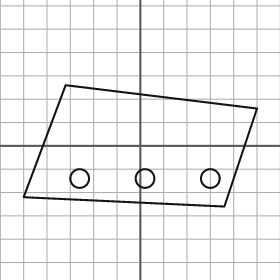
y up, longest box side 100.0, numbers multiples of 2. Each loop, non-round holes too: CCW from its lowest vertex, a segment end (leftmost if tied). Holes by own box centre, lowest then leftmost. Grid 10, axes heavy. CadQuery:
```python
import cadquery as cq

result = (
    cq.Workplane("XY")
    .moveTo(36.0, -26.0)
    .lineTo(50.0, 16.0)
    .lineTo(-32.0, 26.0)
    .lineTo(-50.0, -22.0)
    .close()
    .moveTo(-26.0, -14.0)
    .circle(4.0)
    .moveTo(2.0, -14.0)
    .circle(4.0)
    .moveTo(30.0, -14.0)
    .circle(4.0)
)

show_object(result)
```